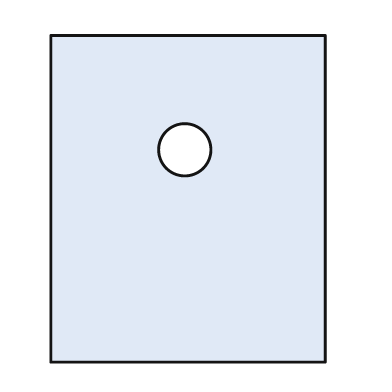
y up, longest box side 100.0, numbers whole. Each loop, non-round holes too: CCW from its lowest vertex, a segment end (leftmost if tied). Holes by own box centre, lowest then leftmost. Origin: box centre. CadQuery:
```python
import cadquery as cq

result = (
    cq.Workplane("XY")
    .moveTo(-42.0, -50.0)
    .lineTo(42.0, -50.0)
    .lineTo(42.0, 50.0)
    .lineTo(-42.0, 50.0)
    .close()
    .moveTo(-1.0, 15.0)
    .circle(8.0)
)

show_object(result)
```